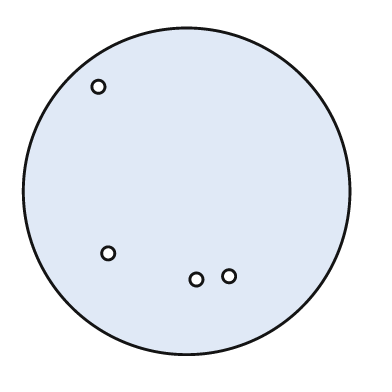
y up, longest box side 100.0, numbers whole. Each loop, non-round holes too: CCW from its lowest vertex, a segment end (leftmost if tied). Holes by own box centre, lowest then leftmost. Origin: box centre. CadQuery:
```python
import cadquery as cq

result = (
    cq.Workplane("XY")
    .moveTo(0.0, 0.0)
    .circle(50.0)
    .moveTo(3.0, -27.0)
    .circle(2.0)
    .moveTo(13.0, -26.0)
    .circle(2.0)
    .moveTo(-24.0, -19.0)
    .circle(2.0)
    .moveTo(-27.0, 32.0)
    .circle(2.0)
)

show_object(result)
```